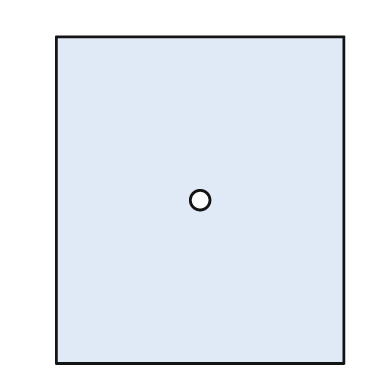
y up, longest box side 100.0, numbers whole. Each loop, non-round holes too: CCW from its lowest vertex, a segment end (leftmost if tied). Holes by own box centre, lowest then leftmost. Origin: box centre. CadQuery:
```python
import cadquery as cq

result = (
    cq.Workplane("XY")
    .moveTo(-44.0, -50.0)
    .lineTo(44.0, -50.0)
    .lineTo(44.0, 50.0)
    .lineTo(-44.0, 50.0)
    .close()
    .moveTo(0.0, 0.0)
    .circle(3.0)
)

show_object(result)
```